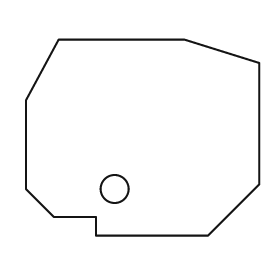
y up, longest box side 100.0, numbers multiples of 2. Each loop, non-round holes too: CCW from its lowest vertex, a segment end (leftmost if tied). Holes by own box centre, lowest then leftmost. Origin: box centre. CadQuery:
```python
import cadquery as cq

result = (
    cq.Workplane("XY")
    .moveTo(-20.0, -42.0)
    .lineTo(28.0, -42.0)
    .lineTo(50.0, -20.0)
    .lineTo(50.0, 32.0)
    .lineTo(18.0, 42.0)
    .lineTo(-36.0, 42.0)
    .lineTo(-50.0, 16.0)
    .lineTo(-50.0, -22.0)
    .lineTo(-38.0, -34.0)
    .lineTo(-20.0, -34.0)
    .close()
    .moveTo(-12.0, -22.0)
    .circle(6.0)
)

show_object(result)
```